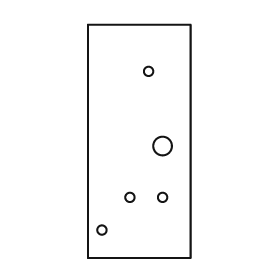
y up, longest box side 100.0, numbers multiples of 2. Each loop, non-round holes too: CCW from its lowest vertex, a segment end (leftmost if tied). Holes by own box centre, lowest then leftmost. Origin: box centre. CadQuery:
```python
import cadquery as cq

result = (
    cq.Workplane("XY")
    .moveTo(-22.0, -50.0)
    .lineTo(22.0, -50.0)
    .lineTo(22.0, 50.0)
    .lineTo(-22.0, 50.0)
    .close()
    .moveTo(-16.0, -38.0)
    .circle(2.0)
    .moveTo(-4.0, -24.0)
    .circle(2.0)
    .moveTo(10.0, -24.0)
    .circle(2.0)
    .moveTo(10.0, -2.0)
    .circle(4.0)
    .moveTo(4.0, 30.0)
    .circle(2.0)
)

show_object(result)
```